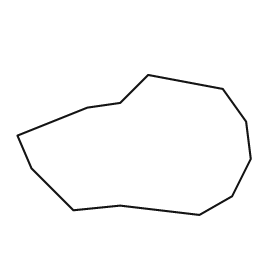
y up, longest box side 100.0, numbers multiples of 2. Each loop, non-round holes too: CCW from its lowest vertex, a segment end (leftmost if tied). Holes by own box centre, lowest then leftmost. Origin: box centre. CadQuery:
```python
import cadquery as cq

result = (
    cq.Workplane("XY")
    .moveTo(28.0, -30.0)
    .lineTo(42.0, -22.0)
    .lineTo(50.0, -6.0)
    .lineTo(48.0, 10.0)
    .lineTo(38.0, 24.0)
    .lineTo(6.0, 30.0)
    .lineTo(-6.0, 18.0)
    .lineTo(-20.0, 16.0)
    .lineTo(-50.0, 4.0)
    .lineTo(-44.0, -10.0)
    .lineTo(-26.0, -28.0)
    .lineTo(-6.0, -26.0)
    .close()
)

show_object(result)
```